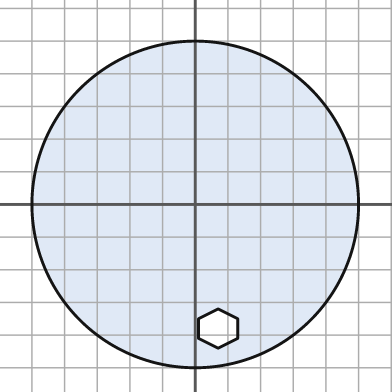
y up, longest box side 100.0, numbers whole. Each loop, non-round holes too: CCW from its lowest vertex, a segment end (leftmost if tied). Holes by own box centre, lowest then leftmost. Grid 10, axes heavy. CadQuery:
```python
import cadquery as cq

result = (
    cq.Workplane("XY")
    .moveTo(0.0, 0.0)
    .circle(50.0)
    .moveTo(7.0, -44.0)
    .lineTo(13.0, -41.0)
    .lineTo(13.0, -35.0)
    .lineTo(7.0, -32.0)
    .lineTo(1.0, -35.0)
    .lineTo(1.0, -41.0)
    .close()
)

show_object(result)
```